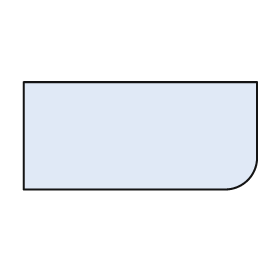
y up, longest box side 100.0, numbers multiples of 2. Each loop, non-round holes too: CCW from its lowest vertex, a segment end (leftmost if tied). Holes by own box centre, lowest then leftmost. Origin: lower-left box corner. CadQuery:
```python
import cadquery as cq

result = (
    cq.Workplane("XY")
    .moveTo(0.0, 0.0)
    .lineTo(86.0, 0.0)
    .threePointArc((96.0, 4.0), (100.0, 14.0))
    .lineTo(100.0, 46.0)
    .lineTo(0.0, 46.0)
    .close()
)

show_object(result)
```